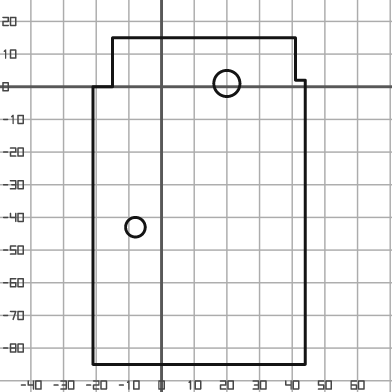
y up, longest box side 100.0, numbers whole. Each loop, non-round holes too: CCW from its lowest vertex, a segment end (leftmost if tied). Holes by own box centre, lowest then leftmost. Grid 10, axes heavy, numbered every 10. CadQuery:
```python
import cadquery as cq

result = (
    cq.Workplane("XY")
    .moveTo(-21.0, -85.0)
    .lineTo(44.0, -85.0)
    .lineTo(44.0, 2.0)
    .lineTo(41.0, 2.0)
    .lineTo(41.0, 15.0)
    .lineTo(-15.0, 15.0)
    .lineTo(-15.0, 0.0)
    .lineTo(-21.0, 0.0)
    .close()
    .moveTo(-8.0, -43.0)
    .circle(3.0)
    .moveTo(20.0, 1.0)
    .circle(4.0)
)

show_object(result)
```